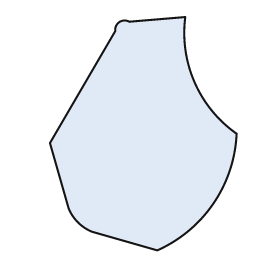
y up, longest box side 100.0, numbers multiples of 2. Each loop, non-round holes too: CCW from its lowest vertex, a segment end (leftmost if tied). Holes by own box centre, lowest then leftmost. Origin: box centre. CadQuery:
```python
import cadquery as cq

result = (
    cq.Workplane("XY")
    .moveTo(6.0, -50.0)
    .threePointArc((30.0, -30.0), (40.0, 0.0))
    .threePointArc((22.0, 22.0), (18.0, 50.0))
    .lineTo(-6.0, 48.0)
    .threePointArc((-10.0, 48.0), (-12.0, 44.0))
    .lineTo(-40.0, -4.0)
    .lineTo(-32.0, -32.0)
    .threePointArc((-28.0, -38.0), (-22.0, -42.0))
    .close()
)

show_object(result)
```